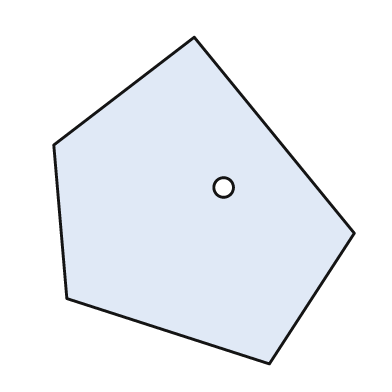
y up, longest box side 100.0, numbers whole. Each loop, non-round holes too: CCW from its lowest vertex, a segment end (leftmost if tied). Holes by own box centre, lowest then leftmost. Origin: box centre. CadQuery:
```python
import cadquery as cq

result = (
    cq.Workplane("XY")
    .moveTo(20.0, -50.0)
    .lineTo(46.0, -10.0)
    .lineTo(-3.0, 50.0)
    .lineTo(-46.0, 17.0)
    .lineTo(-42.0, -30.0)
    .close()
    .moveTo(6.0, 4.0)
    .circle(3.0)
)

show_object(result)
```